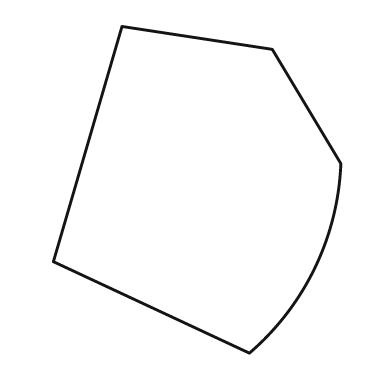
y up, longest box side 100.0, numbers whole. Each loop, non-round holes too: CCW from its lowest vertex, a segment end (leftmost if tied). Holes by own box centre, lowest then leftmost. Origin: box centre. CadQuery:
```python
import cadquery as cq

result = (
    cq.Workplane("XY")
    .moveTo(16.0, -50.0)
    .threePointArc((36.0, -24.0), (44.0, 8.0))
    .lineTo(23.0, 43.0)
    .lineTo(-23.0, 50.0)
    .lineTo(-44.0, -22.0)
    .close()
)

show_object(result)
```